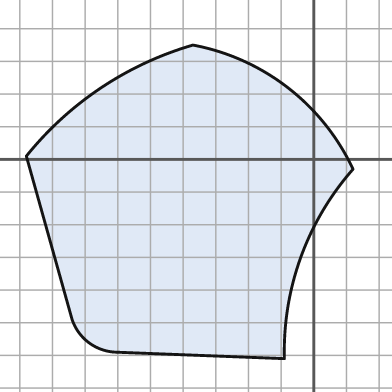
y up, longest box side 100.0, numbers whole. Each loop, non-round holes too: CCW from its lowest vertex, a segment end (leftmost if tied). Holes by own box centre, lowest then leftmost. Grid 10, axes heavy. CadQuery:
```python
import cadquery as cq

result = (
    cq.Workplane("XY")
    .moveTo(-9.0, -61.0)
    .threePointArc((-4.0, -30.0), (12.0, -3.0))
    .threePointArc((-8.0, 22.0), (-37.0, 35.0))
    .threePointArc((-65.0, 22.0), (-88.0, 1.0))
    .lineTo(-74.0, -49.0)
    .threePointArc((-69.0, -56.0), (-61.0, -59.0))
    .close()
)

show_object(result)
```